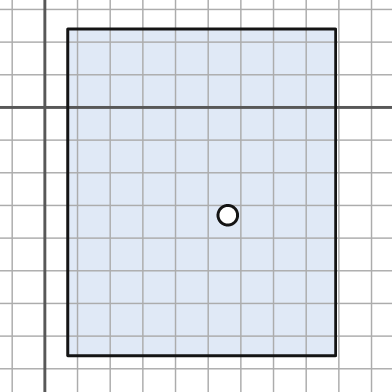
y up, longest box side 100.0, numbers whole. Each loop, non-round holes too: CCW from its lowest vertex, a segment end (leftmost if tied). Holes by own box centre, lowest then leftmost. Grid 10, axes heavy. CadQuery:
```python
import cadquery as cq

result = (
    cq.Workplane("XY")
    .moveTo(7.0, -76.0)
    .lineTo(89.0, -76.0)
    .lineTo(89.0, 24.0)
    .lineTo(7.0, 24.0)
    .close()
    .moveTo(56.0, -33.0)
    .circle(3.0)
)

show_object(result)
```